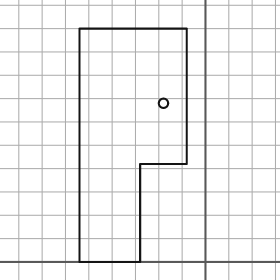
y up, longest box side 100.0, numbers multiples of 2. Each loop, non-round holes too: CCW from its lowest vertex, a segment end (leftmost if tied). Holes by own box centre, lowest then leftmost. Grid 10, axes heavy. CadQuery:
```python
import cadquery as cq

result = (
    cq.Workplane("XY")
    .moveTo(-54.0, 0.0)
    .lineTo(-28.0, 0.0)
    .lineTo(-28.0, 42.0)
    .lineTo(-8.0, 42.0)
    .lineTo(-8.0, 100.0)
    .lineTo(-54.0, 100.0)
    .close()
    .moveTo(-18.0, 68.0)
    .circle(2.0)
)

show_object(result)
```